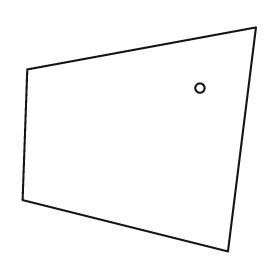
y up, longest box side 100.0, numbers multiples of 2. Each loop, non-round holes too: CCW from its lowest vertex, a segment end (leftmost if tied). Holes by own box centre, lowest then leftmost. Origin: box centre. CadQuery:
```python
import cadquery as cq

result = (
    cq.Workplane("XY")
    .moveTo(38.0, -48.0)
    .lineTo(50.0, 48.0)
    .lineTo(-48.0, 30.0)
    .lineTo(-50.0, -26.0)
    .close()
    .moveTo(26.0, 22.0)
    .circle(2.0)
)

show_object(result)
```